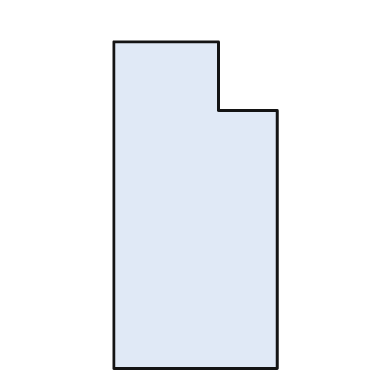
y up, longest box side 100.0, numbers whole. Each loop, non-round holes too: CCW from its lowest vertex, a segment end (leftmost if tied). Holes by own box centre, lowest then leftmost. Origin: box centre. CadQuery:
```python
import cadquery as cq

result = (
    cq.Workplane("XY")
    .moveTo(-25.0, -50.0)
    .lineTo(25.0, -50.0)
    .lineTo(25.0, 29.0)
    .lineTo(7.0, 29.0)
    .lineTo(7.0, 50.0)
    .lineTo(-25.0, 50.0)
    .close()
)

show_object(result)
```